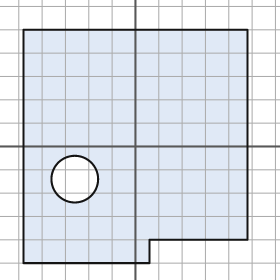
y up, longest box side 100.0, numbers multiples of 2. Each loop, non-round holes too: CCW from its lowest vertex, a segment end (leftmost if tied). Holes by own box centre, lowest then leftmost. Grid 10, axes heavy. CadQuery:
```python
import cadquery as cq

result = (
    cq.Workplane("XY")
    .moveTo(-48.0, -50.0)
    .lineTo(6.0, -50.0)
    .lineTo(6.0, -40.0)
    .lineTo(48.0, -40.0)
    .lineTo(48.0, 50.0)
    .lineTo(-48.0, 50.0)
    .close()
    .moveTo(-26.0, -14.0)
    .circle(10.0)
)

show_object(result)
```